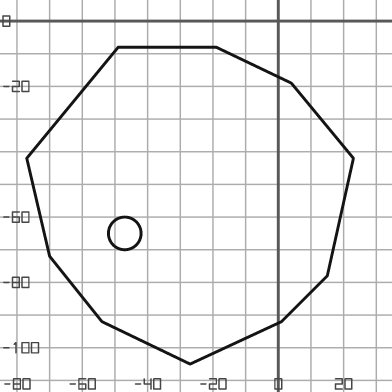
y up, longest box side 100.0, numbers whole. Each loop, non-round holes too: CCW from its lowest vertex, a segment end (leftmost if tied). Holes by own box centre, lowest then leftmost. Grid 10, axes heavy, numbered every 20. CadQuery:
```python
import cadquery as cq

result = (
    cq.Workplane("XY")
    .moveTo(-27.0, -105.0)
    .lineTo(1.0, -92.0)
    .lineTo(15.0, -78.0)
    .lineTo(23.0, -42.0)
    .lineTo(4.0, -19.0)
    .lineTo(-19.0, -8.0)
    .lineTo(-49.0, -8.0)
    .lineTo(-77.0, -42.0)
    .lineTo(-70.0, -72.0)
    .lineTo(-54.0, -92.0)
    .close()
    .moveTo(-47.0, -65.0)
    .circle(5.0)
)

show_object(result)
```